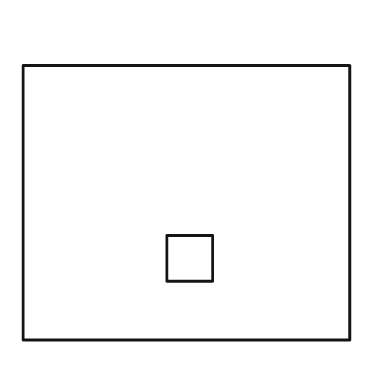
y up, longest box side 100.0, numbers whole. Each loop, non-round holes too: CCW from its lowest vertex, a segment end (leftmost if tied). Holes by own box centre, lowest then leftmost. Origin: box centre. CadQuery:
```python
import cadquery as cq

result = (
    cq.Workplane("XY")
    .moveTo(-50.0, -42.0)
    .lineTo(50.0, -42.0)
    .lineTo(50.0, 42.0)
    .lineTo(-50.0, 42.0)
    .close()
    .moveTo(-6.0, -24.0)
    .lineTo(8.0, -24.0)
    .lineTo(8.0, -10.0)
    .lineTo(-6.0, -10.0)
    .close()
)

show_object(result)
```